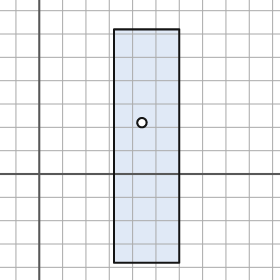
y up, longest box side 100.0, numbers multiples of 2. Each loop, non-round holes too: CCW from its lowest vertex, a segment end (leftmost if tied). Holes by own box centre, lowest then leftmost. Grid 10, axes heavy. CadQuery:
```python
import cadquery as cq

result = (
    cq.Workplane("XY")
    .moveTo(32.0, -38.0)
    .lineTo(60.0, -38.0)
    .lineTo(60.0, 62.0)
    .lineTo(32.0, 62.0)
    .close()
    .moveTo(44.0, 22.0)
    .circle(2.0)
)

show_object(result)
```